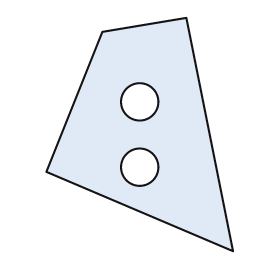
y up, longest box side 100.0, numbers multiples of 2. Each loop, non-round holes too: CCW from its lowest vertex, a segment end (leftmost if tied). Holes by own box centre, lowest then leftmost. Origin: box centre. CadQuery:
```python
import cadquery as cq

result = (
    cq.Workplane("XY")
    .moveTo(40.0, -50.0)
    .lineTo(20.0, 50.0)
    .lineTo(-16.0, 44.0)
    .lineTo(-40.0, -16.0)
    .close()
    .moveTo(0.0, -14.0)
    .circle(8.0)
    .moveTo(0.0, 14.0)
    .circle(8.0)
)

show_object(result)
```